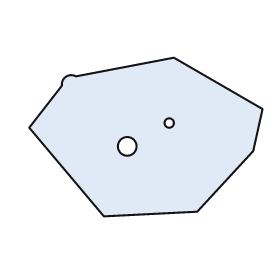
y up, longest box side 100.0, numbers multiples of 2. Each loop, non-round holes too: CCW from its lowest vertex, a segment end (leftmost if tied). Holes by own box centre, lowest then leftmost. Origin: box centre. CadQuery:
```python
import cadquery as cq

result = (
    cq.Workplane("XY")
    .moveTo(-18.0, -34.0)
    .lineTo(22.0, -32.0)
    .lineTo(46.0, -6.0)
    .lineTo(50.0, 12.0)
    .lineTo(12.0, 34.0)
    .lineTo(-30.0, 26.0)
    .threePointArc((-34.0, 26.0), (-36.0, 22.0))
    .lineTo(-50.0, 4.0)
    .close()
    .moveTo(-8.0, -4.0)
    .circle(4.0)
    .moveTo(10.0, 6.0)
    .circle(2.0)
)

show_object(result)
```